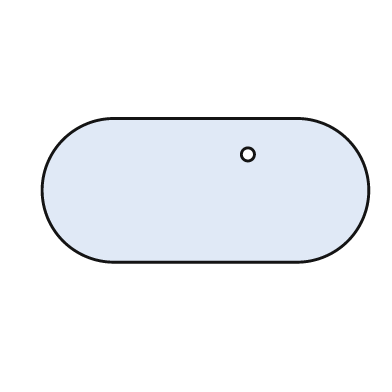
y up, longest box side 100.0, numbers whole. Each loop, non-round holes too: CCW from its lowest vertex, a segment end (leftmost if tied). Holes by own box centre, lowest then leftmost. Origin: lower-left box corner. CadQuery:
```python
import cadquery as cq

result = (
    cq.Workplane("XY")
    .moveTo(22.0, 0.0)
    .lineTo(78.0, 0.0)
    .threePointArc((100.0, 22.0), (78.0, 44.0))
    .lineTo(22.0, 44.0)
    .threePointArc((0.0, 22.0), (22.0, 0.0))
    .close()
    .moveTo(63.0, 33.0)
    .circle(2.0)
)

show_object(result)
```